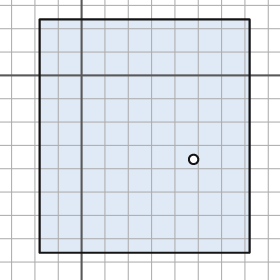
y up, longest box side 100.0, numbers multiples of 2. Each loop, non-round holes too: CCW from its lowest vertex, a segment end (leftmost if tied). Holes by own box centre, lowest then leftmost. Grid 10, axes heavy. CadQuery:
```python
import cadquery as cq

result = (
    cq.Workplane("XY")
    .moveTo(-18.0, -76.0)
    .lineTo(72.0, -76.0)
    .lineTo(72.0, 24.0)
    .lineTo(-18.0, 24.0)
    .close()
    .moveTo(48.0, -36.0)
    .circle(2.0)
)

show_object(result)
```